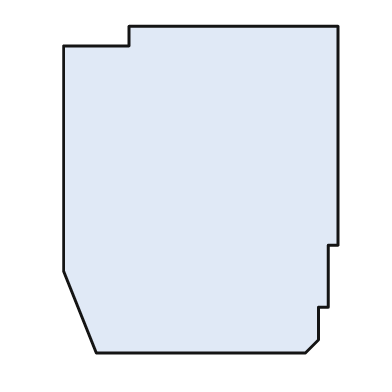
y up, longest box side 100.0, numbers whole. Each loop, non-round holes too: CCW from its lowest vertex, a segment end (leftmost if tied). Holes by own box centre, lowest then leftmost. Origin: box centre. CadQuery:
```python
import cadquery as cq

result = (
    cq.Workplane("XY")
    .moveTo(-32.0, -50.0)
    .lineTo(32.0, -50.0)
    .lineTo(36.0, -46.0)
    .lineTo(36.0, -36.0)
    .lineTo(39.0, -36.0)
    .lineTo(39.0, -17.0)
    .lineTo(42.0, -17.0)
    .lineTo(42.0, 50.0)
    .lineTo(-22.0, 50.0)
    .lineTo(-22.0, 44.0)
    .lineTo(-42.0, 44.0)
    .lineTo(-42.0, -25.0)
    .close()
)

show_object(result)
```